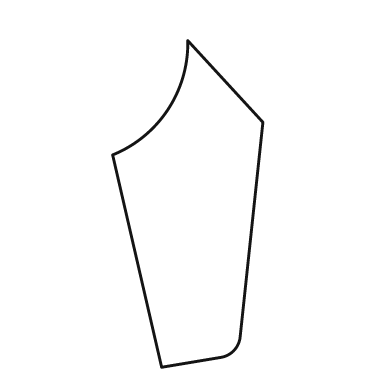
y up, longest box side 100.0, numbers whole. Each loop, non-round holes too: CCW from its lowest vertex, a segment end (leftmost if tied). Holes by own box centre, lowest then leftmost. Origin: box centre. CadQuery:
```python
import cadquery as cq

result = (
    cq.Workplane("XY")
    .moveTo(-8.0, -50.0)
    .lineTo(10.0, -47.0)
    .threePointArc((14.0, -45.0), (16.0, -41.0))
    .lineTo(23.0, 25.0)
    .lineTo(0.0, 50.0)
    .threePointArc((-6.0, 29.0), (-23.0, 15.0))
    .close()
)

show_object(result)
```